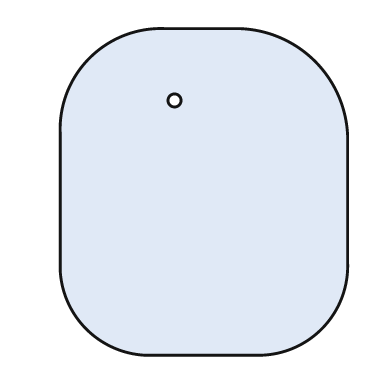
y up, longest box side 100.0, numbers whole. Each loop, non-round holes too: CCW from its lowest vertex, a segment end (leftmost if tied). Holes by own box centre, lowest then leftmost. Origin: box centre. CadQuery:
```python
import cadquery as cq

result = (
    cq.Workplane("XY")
    .moveTo(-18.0, -50.0)
    .lineTo(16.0, -50.0)
    .threePointArc((36.0, -42.0), (44.0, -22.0))
    .lineTo(44.0, 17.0)
    .threePointArc((34.0, 40.0), (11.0, 50.0))
    .lineTo(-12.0, 50.0)
    .threePointArc((-35.0, 41.0), (-44.0, 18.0))
    .lineTo(-44.0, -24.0)
    .threePointArc((-36.0, -42.0), (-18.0, -50.0))
    .close()
    .moveTo(-9.0, 28.0)
    .circle(2.0)
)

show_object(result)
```